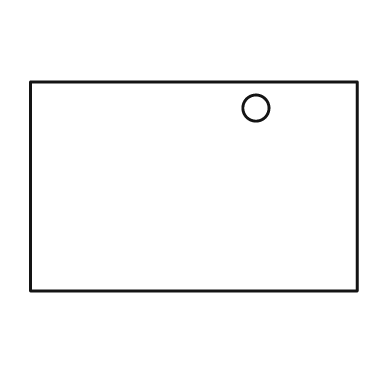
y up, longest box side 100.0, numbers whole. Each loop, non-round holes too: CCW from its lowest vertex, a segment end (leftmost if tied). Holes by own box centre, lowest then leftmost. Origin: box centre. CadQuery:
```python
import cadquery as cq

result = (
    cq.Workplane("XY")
    .moveTo(-50.0, -32.0)
    .lineTo(50.0, -32.0)
    .lineTo(50.0, 32.0)
    .lineTo(-50.0, 32.0)
    .close()
    .moveTo(19.0, 24.0)
    .circle(4.0)
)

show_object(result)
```